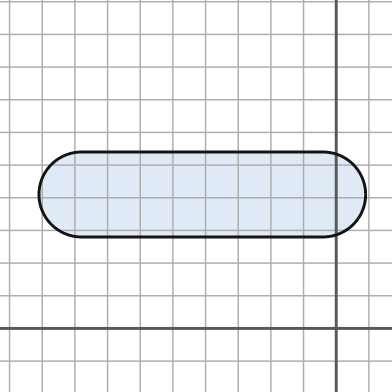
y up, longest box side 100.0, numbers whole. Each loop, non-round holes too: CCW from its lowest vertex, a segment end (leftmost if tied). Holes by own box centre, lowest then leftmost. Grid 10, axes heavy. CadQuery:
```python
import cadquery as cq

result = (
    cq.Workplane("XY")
    .moveTo(-78.0, 28.0)
    .lineTo(-4.0, 28.0)
    .threePointArc((9.0, 41.0), (-4.0, 54.0))
    .lineTo(-78.0, 54.0)
    .threePointArc((-91.0, 41.0), (-78.0, 28.0))
    .close()
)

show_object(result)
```